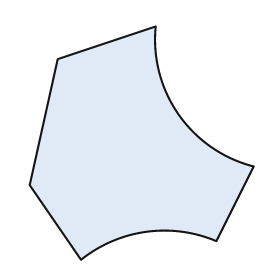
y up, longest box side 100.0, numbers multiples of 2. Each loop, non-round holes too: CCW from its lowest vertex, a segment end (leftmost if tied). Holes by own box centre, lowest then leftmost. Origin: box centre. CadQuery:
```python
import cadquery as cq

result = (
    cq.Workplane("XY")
    .moveTo(-26.0, -50.0)
    .threePointArc((2.0, -38.0), (32.0, -42.0))
    .lineTo(48.0, -10.0)
    .threePointArc((16.0, 12.0), (6.0, 50.0))
    .lineTo(-36.0, 36.0)
    .lineTo(-48.0, -18.0)
    .close()
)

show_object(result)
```